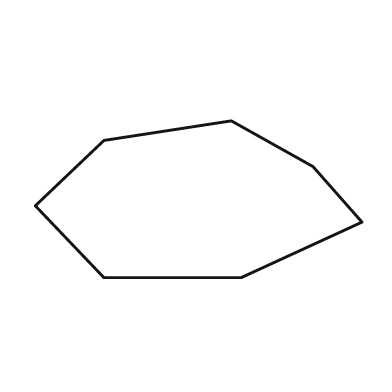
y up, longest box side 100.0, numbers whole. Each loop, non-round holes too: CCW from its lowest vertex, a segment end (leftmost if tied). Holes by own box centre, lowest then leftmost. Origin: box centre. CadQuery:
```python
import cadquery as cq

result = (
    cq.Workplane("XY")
    .moveTo(-29.0, -24.0)
    .lineTo(13.0, -24.0)
    .lineTo(50.0, -7.0)
    .lineTo(35.0, 10.0)
    .lineTo(10.0, 24.0)
    .lineTo(-29.0, 18.0)
    .lineTo(-50.0, -2.0)
    .close()
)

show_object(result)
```